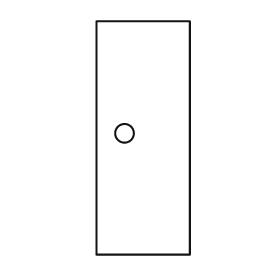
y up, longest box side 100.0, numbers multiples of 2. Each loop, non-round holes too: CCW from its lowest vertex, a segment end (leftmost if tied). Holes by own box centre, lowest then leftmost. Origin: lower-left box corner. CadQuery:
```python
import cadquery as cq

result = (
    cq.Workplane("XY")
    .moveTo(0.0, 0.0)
    .lineTo(40.0, 0.0)
    .lineTo(40.0, 100.0)
    .lineTo(0.0, 100.0)
    .close()
    .moveTo(12.0, 52.0)
    .circle(4.0)
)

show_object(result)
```